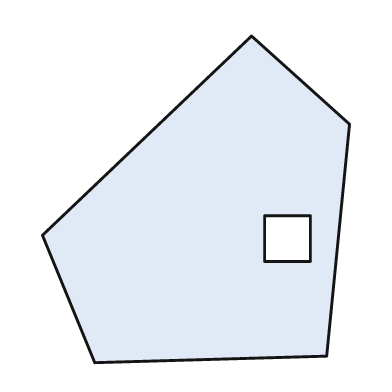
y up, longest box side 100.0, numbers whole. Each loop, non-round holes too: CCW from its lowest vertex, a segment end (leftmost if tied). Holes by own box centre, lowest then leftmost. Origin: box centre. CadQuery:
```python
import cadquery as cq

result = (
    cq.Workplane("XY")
    .moveTo(-31.0, -50.0)
    .lineTo(40.0, -48.0)
    .lineTo(47.0, 23.0)
    .lineTo(17.0, 50.0)
    .lineTo(-47.0, -11.0)
    .close()
    .moveTo(21.0, -19.0)
    .lineTo(35.0, -19.0)
    .lineTo(35.0, -5.0)
    .lineTo(21.0, -5.0)
    .close()
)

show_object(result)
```